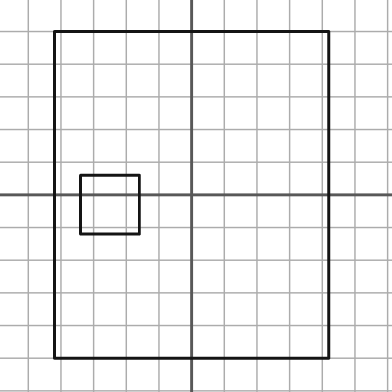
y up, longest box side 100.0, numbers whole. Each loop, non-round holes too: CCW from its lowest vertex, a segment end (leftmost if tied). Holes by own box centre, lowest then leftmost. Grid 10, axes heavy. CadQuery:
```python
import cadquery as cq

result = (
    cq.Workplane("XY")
    .moveTo(-42.0, -50.0)
    .lineTo(42.0, -50.0)
    .lineTo(42.0, 50.0)
    .lineTo(-42.0, 50.0)
    .close()
    .moveTo(-34.0, -12.0)
    .lineTo(-16.0, -12.0)
    .lineTo(-16.0, 6.0)
    .lineTo(-34.0, 6.0)
    .close()
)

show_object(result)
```